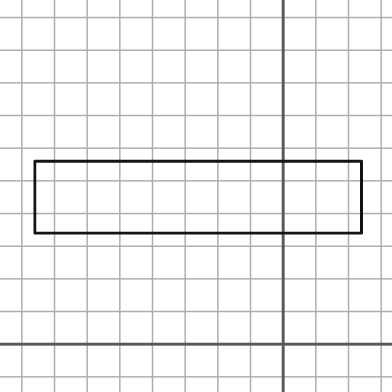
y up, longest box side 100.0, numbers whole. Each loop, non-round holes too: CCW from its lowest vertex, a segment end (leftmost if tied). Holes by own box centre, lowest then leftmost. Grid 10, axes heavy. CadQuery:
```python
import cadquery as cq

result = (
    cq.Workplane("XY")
    .moveTo(-76.0, 34.0)
    .lineTo(24.0, 34.0)
    .lineTo(24.0, 56.0)
    .lineTo(-76.0, 56.0)
    .close()
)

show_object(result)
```